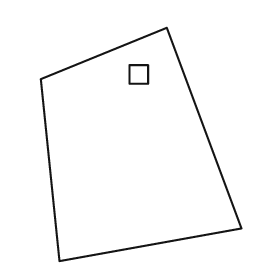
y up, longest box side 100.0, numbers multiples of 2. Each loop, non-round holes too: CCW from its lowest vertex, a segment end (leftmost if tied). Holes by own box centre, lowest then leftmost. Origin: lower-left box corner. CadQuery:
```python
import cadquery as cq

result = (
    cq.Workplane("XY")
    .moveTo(8.0, 0.0)
    .lineTo(86.0, 14.0)
    .lineTo(54.0, 100.0)
    .lineTo(0.0, 78.0)
    .close()
    .moveTo(38.0, 76.0)
    .lineTo(46.0, 76.0)
    .lineTo(46.0, 84.0)
    .lineTo(38.0, 84.0)
    .close()
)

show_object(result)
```